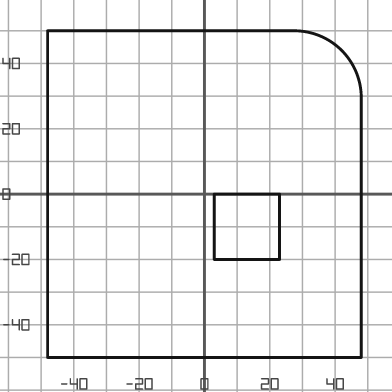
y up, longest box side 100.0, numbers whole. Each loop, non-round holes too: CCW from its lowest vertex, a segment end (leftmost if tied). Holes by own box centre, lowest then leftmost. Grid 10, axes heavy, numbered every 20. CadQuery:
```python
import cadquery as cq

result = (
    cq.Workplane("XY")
    .moveTo(-48.0, -50.0)
    .lineTo(48.0, -50.0)
    .lineTo(48.0, 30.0)
    .threePointArc((42.0, 44.0), (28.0, 50.0))
    .lineTo(-48.0, 50.0)
    .close()
    .moveTo(3.0, -20.0)
    .lineTo(23.0, -20.0)
    .lineTo(23.0, 0.0)
    .lineTo(3.0, 0.0)
    .close()
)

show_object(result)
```